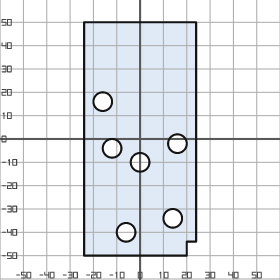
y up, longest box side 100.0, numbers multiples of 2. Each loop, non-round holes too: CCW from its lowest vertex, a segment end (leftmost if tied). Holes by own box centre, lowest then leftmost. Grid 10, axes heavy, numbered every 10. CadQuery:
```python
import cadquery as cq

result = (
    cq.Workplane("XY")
    .moveTo(-24.0, -50.0)
    .lineTo(20.0, -50.0)
    .lineTo(20.0, -44.0)
    .lineTo(24.0, -44.0)
    .lineTo(24.0, 50.0)
    .lineTo(-24.0, 50.0)
    .close()
    .moveTo(-6.0, -40.0)
    .circle(4.0)
    .moveTo(14.0, -34.0)
    .circle(4.0)
    .moveTo(0.0, -10.0)
    .circle(4.0)
    .moveTo(-12.0, -4.0)
    .circle(4.0)
    .moveTo(16.0, -2.0)
    .circle(4.0)
    .moveTo(-16.0, 16.0)
    .circle(4.0)
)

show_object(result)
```